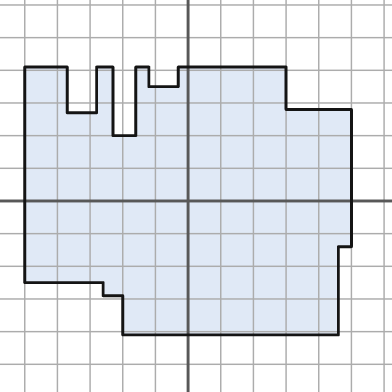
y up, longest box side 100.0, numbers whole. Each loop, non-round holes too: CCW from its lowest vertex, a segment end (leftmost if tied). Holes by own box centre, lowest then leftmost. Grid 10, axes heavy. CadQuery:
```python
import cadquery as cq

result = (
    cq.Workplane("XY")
    .moveTo(-20.0, -41.0)
    .lineTo(46.0, -41.0)
    .lineTo(46.0, -14.0)
    .lineTo(50.0, -14.0)
    .lineTo(50.0, 28.0)
    .lineTo(30.0, 28.0)
    .lineTo(30.0, 41.0)
    .lineTo(-3.0, 41.0)
    .lineTo(-3.0, 35.0)
    .lineTo(-12.0, 35.0)
    .lineTo(-12.0, 41.0)
    .lineTo(-16.0, 41.0)
    .lineTo(-16.0, 20.0)
    .lineTo(-23.0, 20.0)
    .lineTo(-23.0, 41.0)
    .lineTo(-28.0, 41.0)
    .lineTo(-28.0, 27.0)
    .lineTo(-37.0, 27.0)
    .lineTo(-37.0, 41.0)
    .lineTo(-50.0, 41.0)
    .lineTo(-50.0, -25.0)
    .lineTo(-26.0, -25.0)
    .lineTo(-26.0, -29.0)
    .lineTo(-20.0, -29.0)
    .close()
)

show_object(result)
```